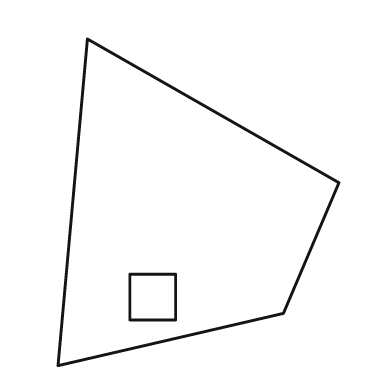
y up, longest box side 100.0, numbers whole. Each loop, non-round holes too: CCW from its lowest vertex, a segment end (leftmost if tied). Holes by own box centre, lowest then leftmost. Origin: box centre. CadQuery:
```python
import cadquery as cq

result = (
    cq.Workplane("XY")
    .moveTo(-43.0, -50.0)
    .lineTo(26.0, -34.0)
    .lineTo(43.0, 6.0)
    .lineTo(-34.0, 50.0)
    .close()
    .moveTo(-21.0, -36.0)
    .lineTo(-7.0, -36.0)
    .lineTo(-7.0, -22.0)
    .lineTo(-21.0, -22.0)
    .close()
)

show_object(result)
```